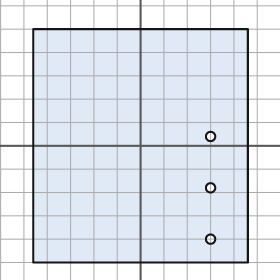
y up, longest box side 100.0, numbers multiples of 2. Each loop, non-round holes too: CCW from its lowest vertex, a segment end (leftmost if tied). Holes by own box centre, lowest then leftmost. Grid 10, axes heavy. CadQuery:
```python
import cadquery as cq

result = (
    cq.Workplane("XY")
    .moveTo(-46.0, -50.0)
    .lineTo(46.0, -50.0)
    .lineTo(46.0, 50.0)
    .lineTo(-46.0, 50.0)
    .close()
    .moveTo(30.0, -40.0)
    .circle(2.0)
    .moveTo(30.0, -18.0)
    .circle(2.0)
    .moveTo(30.0, 4.0)
    .circle(2.0)
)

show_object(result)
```